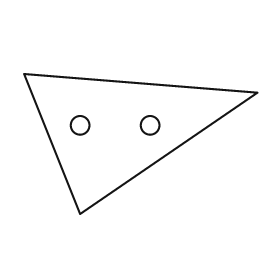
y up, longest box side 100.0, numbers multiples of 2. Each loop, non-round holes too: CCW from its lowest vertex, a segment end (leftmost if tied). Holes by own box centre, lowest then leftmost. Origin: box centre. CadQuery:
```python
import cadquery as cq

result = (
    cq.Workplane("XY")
    .moveTo(-26.0, -30.0)
    .lineTo(50.0, 22.0)
    .lineTo(-50.0, 30.0)
    .close()
    .moveTo(-26.0, 8.0)
    .circle(4.0)
    .moveTo(4.0, 8.0)
    .circle(4.0)
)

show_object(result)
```